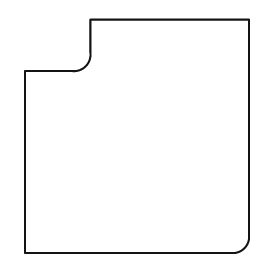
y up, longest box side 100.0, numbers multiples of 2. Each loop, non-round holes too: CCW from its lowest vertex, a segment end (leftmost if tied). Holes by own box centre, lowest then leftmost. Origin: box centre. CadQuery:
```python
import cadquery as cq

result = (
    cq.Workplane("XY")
    .moveTo(-48.0, -50.0)
    .lineTo(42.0, -50.0)
    .threePointArc((46.0, -48.0), (48.0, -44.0))
    .lineTo(48.0, 50.0)
    .lineTo(-20.0, 50.0)
    .lineTo(-20.0, 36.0)
    .threePointArc((-22.0, 30.0), (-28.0, 28.0))
    .lineTo(-48.0, 28.0)
    .close()
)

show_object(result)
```